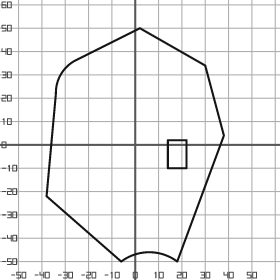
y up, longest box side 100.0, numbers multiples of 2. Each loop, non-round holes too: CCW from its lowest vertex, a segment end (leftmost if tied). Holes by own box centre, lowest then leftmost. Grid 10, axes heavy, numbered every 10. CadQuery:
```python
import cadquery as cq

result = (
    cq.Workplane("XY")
    .moveTo(-6.0, -50.0)
    .threePointArc((6.0, -46.0), (18.0, -50.0))
    .lineTo(38.0, 4.0)
    .lineTo(30.0, 34.0)
    .lineTo(2.0, 50.0)
    .lineTo(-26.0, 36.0)
    .threePointArc((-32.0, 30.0), (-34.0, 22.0))
    .lineTo(-38.0, -22.0)
    .close()
    .moveTo(14.0, -10.0)
    .lineTo(22.0, -10.0)
    .lineTo(22.0, 2.0)
    .lineTo(14.0, 2.0)
    .close()
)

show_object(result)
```